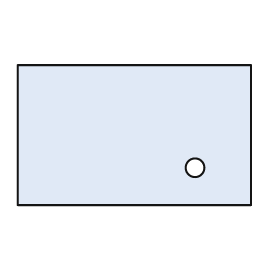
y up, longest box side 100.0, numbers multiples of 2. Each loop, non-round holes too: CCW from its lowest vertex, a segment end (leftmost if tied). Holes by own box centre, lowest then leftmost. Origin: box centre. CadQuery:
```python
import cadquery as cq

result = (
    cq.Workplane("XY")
    .moveTo(-50.0, -30.0)
    .lineTo(50.0, -30.0)
    .lineTo(50.0, 30.0)
    .lineTo(-50.0, 30.0)
    .close()
    .moveTo(26.0, -14.0)
    .circle(4.0)
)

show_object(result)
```